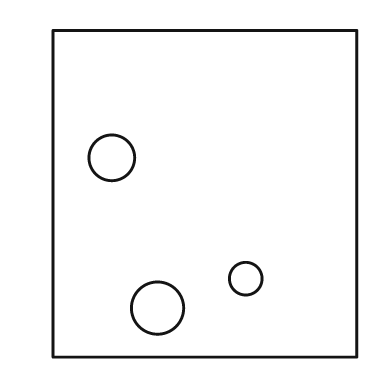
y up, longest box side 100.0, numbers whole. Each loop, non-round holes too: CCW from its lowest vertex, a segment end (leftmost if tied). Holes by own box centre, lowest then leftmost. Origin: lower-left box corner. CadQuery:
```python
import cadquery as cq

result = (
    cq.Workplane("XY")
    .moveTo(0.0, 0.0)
    .lineTo(93.0, 0.0)
    .lineTo(93.0, 100.0)
    .lineTo(0.0, 100.0)
    .close()
    .moveTo(32.0, 15.0)
    .circle(8.0)
    .moveTo(59.0, 24.0)
    .circle(5.0)
    .moveTo(18.0, 61.0)
    .circle(7.0)
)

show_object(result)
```